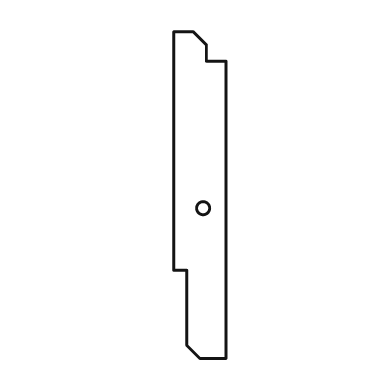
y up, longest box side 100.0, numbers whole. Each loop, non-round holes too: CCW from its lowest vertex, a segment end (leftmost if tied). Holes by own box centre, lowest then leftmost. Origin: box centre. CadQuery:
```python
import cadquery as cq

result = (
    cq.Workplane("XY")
    .moveTo(0.0, -50.0)
    .lineTo(8.0, -50.0)
    .lineTo(8.0, 41.0)
    .lineTo(2.0, 41.0)
    .lineTo(2.0, 46.0)
    .lineTo(-2.0, 50.0)
    .lineTo(-8.0, 50.0)
    .lineTo(-8.0, -23.0)
    .lineTo(-4.0, -23.0)
    .lineTo(-4.0, -46.0)
    .close()
    .moveTo(1.0, -4.0)
    .circle(2.0)
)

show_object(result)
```